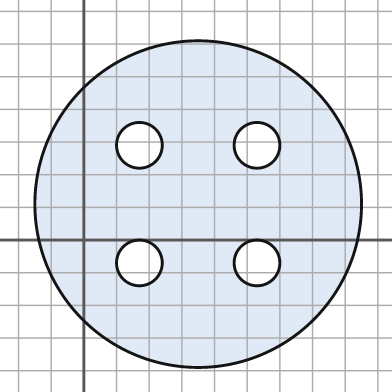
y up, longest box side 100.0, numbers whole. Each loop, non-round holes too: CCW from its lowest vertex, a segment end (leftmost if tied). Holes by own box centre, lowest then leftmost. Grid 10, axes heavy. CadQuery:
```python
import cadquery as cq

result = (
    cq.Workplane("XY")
    .moveTo(35.0, 11.0)
    .circle(50.0)
    .moveTo(17.0, -7.0)
    .circle(7.0)
    .moveTo(53.0, -7.0)
    .circle(7.0)
    .moveTo(17.0, 29.0)
    .circle(7.0)
    .moveTo(53.0, 29.0)
    .circle(7.0)
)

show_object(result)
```